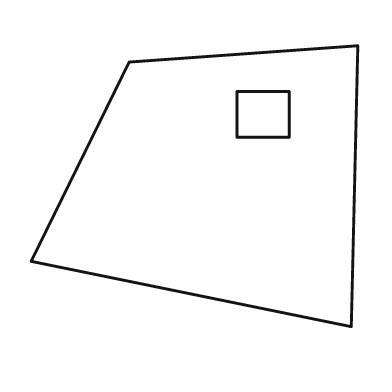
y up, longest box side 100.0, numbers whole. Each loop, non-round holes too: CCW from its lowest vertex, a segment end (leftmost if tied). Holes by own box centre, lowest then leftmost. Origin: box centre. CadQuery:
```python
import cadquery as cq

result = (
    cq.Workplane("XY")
    .moveTo(48.0, -43.0)
    .lineTo(50.0, 43.0)
    .lineTo(-20.0, 38.0)
    .lineTo(-50.0, -23.0)
    .close()
    .moveTo(13.0, 15.0)
    .lineTo(29.0, 15.0)
    .lineTo(29.0, 29.0)
    .lineTo(13.0, 29.0)
    .close()
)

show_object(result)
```